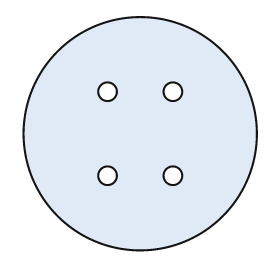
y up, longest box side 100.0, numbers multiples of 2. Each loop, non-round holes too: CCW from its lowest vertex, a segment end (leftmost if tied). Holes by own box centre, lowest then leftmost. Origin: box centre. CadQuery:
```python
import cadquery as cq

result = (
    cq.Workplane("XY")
    .moveTo(0.0, 0.0)
    .circle(50.0)
    .moveTo(-14.0, -18.0)
    .circle(4.0)
    .moveTo(14.0, -18.0)
    .circle(4.0)
    .moveTo(-14.0, 18.0)
    .circle(4.0)
    .moveTo(14.0, 18.0)
    .circle(4.0)
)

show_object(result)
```